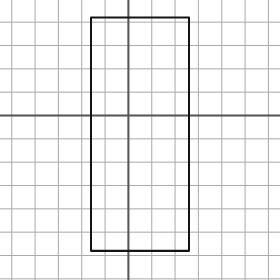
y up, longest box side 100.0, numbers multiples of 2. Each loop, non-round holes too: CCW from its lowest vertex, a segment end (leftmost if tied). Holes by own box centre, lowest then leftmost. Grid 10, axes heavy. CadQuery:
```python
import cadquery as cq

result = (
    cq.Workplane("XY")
    .moveTo(-16.0, -58.0)
    .lineTo(26.0, -58.0)
    .lineTo(26.0, 42.0)
    .lineTo(-16.0, 42.0)
    .close()
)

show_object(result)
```